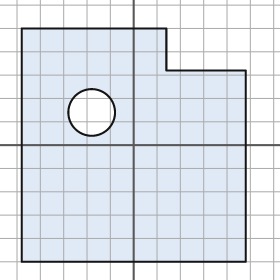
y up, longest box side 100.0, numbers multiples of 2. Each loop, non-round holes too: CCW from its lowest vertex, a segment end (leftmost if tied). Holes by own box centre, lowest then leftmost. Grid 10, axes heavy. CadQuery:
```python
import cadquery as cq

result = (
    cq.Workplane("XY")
    .moveTo(-48.0, -50.0)
    .lineTo(48.0, -50.0)
    .lineTo(48.0, 32.0)
    .lineTo(14.0, 32.0)
    .lineTo(14.0, 50.0)
    .lineTo(-48.0, 50.0)
    .close()
    .moveTo(-18.0, 14.0)
    .circle(10.0)
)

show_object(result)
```